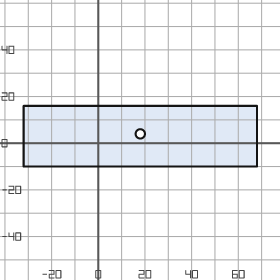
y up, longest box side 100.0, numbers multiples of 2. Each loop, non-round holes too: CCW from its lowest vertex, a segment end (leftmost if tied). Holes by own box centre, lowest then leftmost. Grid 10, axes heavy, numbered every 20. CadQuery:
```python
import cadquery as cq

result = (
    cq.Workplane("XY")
    .moveTo(-32.0, -10.0)
    .lineTo(68.0, -10.0)
    .lineTo(68.0, 16.0)
    .lineTo(-32.0, 16.0)
    .close()
    .moveTo(18.0, 4.0)
    .circle(2.0)
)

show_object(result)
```